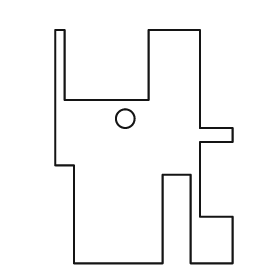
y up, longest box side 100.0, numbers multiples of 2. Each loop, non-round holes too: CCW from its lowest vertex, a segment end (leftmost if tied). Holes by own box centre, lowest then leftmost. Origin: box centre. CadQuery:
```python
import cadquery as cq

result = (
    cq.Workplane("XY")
    .moveTo(-30.0, -50.0)
    .lineTo(8.0, -50.0)
    .lineTo(8.0, -12.0)
    .lineTo(20.0, -12.0)
    .lineTo(20.0, -50.0)
    .lineTo(38.0, -50.0)
    .lineTo(38.0, -30.0)
    .lineTo(24.0, -30.0)
    .lineTo(24.0, 2.0)
    .lineTo(38.0, 2.0)
    .lineTo(38.0, 8.0)
    .lineTo(24.0, 8.0)
    .lineTo(24.0, 50.0)
    .lineTo(2.0, 50.0)
    .lineTo(2.0, 20.0)
    .lineTo(-34.0, 20.0)
    .lineTo(-34.0, 50.0)
    .lineTo(-38.0, 50.0)
    .lineTo(-38.0, -8.0)
    .lineTo(-30.0, -8.0)
    .close()
    .moveTo(-8.0, 12.0)
    .circle(4.0)
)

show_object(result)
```